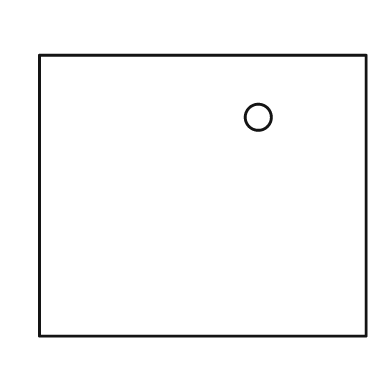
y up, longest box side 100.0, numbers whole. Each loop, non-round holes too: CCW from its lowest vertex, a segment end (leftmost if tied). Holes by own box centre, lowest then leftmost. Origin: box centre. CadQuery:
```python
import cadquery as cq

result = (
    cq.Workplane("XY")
    .moveTo(-50.0, -43.0)
    .lineTo(50.0, -43.0)
    .lineTo(50.0, 43.0)
    .lineTo(-50.0, 43.0)
    .close()
    .moveTo(17.0, 24.0)
    .circle(4.0)
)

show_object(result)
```